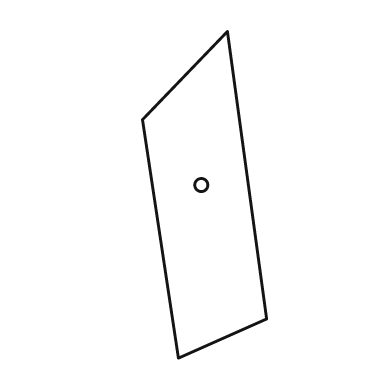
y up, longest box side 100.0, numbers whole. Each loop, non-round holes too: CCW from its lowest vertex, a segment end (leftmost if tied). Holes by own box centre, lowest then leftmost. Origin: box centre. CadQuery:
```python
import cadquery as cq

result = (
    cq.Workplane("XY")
    .moveTo(-8.0, -50.0)
    .lineTo(19.0, -38.0)
    .lineTo(7.0, 50.0)
    .lineTo(-19.0, 23.0)
    .close()
    .moveTo(-1.0, 3.0)
    .circle(2.0)
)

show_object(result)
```